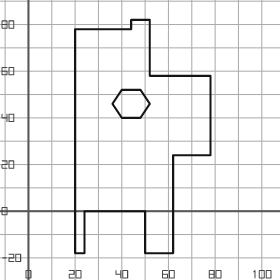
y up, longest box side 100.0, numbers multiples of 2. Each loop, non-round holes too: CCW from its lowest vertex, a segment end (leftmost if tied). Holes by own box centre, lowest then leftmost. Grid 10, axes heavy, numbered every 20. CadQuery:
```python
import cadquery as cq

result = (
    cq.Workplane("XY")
    .moveTo(20.0, -18.0)
    .lineTo(24.0, -18.0)
    .lineTo(24.0, 0.0)
    .lineTo(50.0, 0.0)
    .lineTo(50.0, -18.0)
    .lineTo(62.0, -18.0)
    .lineTo(62.0, 24.0)
    .lineTo(78.0, 24.0)
    .lineTo(78.0, 58.0)
    .lineTo(52.0, 58.0)
    .lineTo(52.0, 82.0)
    .lineTo(44.0, 82.0)
    .lineTo(44.0, 78.0)
    .lineTo(20.0, 78.0)
    .close()
    .moveTo(40.0, 40.0)
    .lineTo(48.0, 40.0)
    .lineTo(52.0, 46.0)
    .lineTo(48.0, 52.0)
    .lineTo(40.0, 52.0)
    .lineTo(36.0, 46.0)
    .close()
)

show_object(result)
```